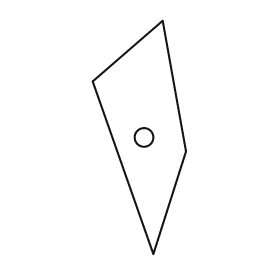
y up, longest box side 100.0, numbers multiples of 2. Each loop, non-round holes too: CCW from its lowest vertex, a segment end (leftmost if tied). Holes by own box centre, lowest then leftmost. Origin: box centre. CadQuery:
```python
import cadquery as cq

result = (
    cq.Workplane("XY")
    .moveTo(6.0, -50.0)
    .lineTo(20.0, -6.0)
    .lineTo(10.0, 50.0)
    .lineTo(-20.0, 24.0)
    .close()
    .moveTo(2.0, 0.0)
    .circle(4.0)
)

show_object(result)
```